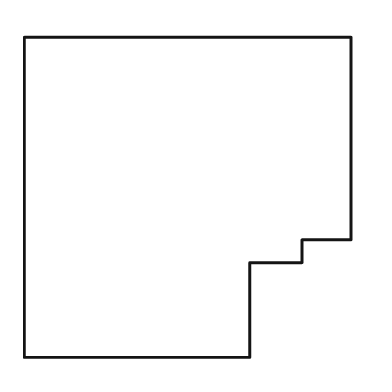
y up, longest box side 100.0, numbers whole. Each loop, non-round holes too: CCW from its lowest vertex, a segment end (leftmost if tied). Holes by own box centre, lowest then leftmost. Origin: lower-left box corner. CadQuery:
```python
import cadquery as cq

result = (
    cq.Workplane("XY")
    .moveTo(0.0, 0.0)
    .lineTo(69.0, 0.0)
    .lineTo(69.0, 29.0)
    .lineTo(85.0, 29.0)
    .lineTo(85.0, 36.0)
    .lineTo(100.0, 36.0)
    .lineTo(100.0, 98.0)
    .lineTo(0.0, 98.0)
    .close()
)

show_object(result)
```